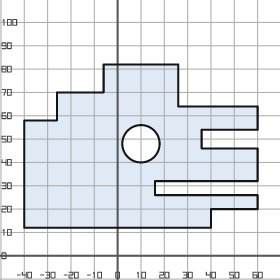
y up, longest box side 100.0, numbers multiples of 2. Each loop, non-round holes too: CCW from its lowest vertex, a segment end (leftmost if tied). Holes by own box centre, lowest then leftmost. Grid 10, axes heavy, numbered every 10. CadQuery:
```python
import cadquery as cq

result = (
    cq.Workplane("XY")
    .moveTo(-40.0, 12.0)
    .lineTo(40.0, 12.0)
    .lineTo(40.0, 20.0)
    .lineTo(60.0, 20.0)
    .lineTo(60.0, 26.0)
    .lineTo(16.0, 26.0)
    .lineTo(16.0, 32.0)
    .lineTo(60.0, 32.0)
    .lineTo(60.0, 46.0)
    .lineTo(36.0, 46.0)
    .lineTo(36.0, 54.0)
    .lineTo(60.0, 54.0)
    .lineTo(60.0, 64.0)
    .lineTo(26.0, 64.0)
    .lineTo(26.0, 82.0)
    .lineTo(-6.0, 82.0)
    .lineTo(-6.0, 70.0)
    .lineTo(-26.0, 70.0)
    .lineTo(-26.0, 58.0)
    .lineTo(-40.0, 58.0)
    .close()
    .moveTo(10.0, 48.0)
    .circle(8.0)
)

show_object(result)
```